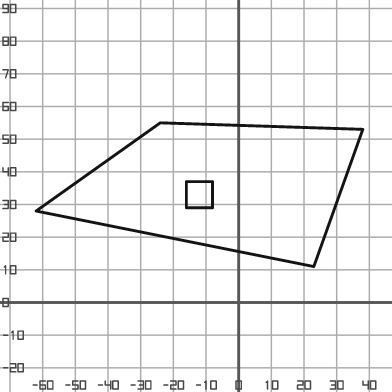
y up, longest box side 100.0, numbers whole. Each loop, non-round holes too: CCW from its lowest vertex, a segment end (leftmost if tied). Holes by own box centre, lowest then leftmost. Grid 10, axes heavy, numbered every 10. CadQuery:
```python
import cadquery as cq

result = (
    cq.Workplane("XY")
    .moveTo(23.0, 11.0)
    .lineTo(38.0, 53.0)
    .lineTo(-24.0, 55.0)
    .lineTo(-62.0, 28.0)
    .close()
    .moveTo(-16.0, 29.0)
    .lineTo(-8.0, 29.0)
    .lineTo(-8.0, 37.0)
    .lineTo(-16.0, 37.0)
    .close()
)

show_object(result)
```